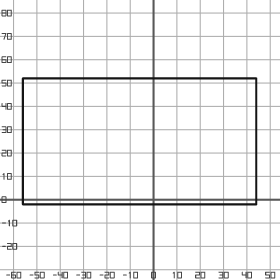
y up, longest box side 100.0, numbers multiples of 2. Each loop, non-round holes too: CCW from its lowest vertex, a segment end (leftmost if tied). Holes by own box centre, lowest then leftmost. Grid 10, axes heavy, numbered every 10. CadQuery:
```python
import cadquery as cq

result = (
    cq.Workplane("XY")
    .moveTo(-56.0, -2.0)
    .lineTo(44.0, -2.0)
    .lineTo(44.0, 52.0)
    .lineTo(-56.0, 52.0)
    .close()
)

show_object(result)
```